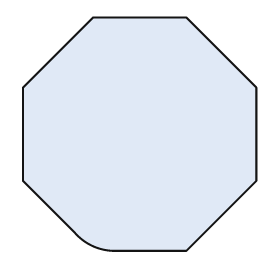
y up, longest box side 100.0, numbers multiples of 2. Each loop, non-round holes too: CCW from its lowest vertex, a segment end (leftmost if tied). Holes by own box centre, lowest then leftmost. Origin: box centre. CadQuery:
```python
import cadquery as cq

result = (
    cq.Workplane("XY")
    .moveTo(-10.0, -50.0)
    .lineTo(20.0, -50.0)
    .lineTo(50.0, -20.0)
    .lineTo(50.0, 20.0)
    .lineTo(20.0, 50.0)
    .lineTo(-20.0, 50.0)
    .lineTo(-50.0, 20.0)
    .lineTo(-50.0, -20.0)
    .lineTo(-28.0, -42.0)
    .threePointArc((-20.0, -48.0), (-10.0, -50.0))
    .close()
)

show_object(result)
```